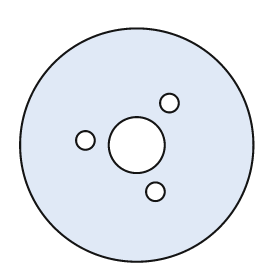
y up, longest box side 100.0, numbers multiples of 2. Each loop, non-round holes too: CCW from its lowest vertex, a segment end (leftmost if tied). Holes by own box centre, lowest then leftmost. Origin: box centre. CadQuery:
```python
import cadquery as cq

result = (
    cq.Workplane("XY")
    .moveTo(0.0, 0.0)
    .circle(50.0)
    .moveTo(8.0, -20.0)
    .circle(4.0)
    .moveTo(0.0, 0.0)
    .circle(12.0)
    .moveTo(-22.0, 2.0)
    .circle(4.0)
    .moveTo(14.0, 18.0)
    .circle(4.0)
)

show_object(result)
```